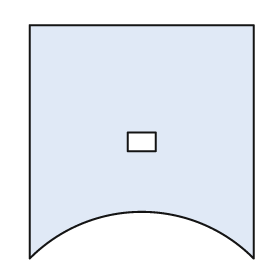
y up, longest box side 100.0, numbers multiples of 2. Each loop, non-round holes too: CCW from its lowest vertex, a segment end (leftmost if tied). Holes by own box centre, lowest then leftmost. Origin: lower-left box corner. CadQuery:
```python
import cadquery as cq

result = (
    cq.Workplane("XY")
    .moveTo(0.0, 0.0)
    .threePointArc((48.0, 20.0), (96.0, 0.0))
    .lineTo(96.0, 100.0)
    .lineTo(0.0, 100.0)
    .close()
    .moveTo(42.0, 46.0)
    .lineTo(54.0, 46.0)
    .lineTo(54.0, 54.0)
    .lineTo(42.0, 54.0)
    .close()
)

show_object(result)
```